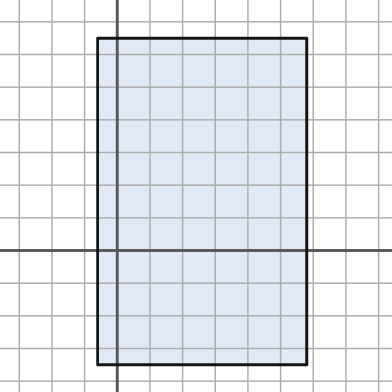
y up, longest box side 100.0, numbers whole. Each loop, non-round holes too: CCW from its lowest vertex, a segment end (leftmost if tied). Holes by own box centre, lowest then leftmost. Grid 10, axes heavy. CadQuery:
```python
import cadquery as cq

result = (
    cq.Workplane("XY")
    .moveTo(-6.0, -35.0)
    .lineTo(58.0, -35.0)
    .lineTo(58.0, 65.0)
    .lineTo(-6.0, 65.0)
    .close()
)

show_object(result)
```